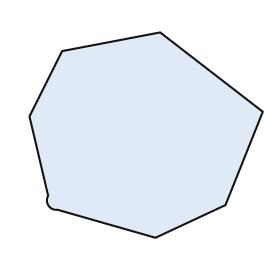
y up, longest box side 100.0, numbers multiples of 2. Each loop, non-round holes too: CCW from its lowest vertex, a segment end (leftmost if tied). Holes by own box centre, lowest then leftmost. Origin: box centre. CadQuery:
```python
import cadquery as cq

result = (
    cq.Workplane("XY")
    .moveTo(4.0, -44.0)
    .lineTo(34.0, -30.0)
    .lineTo(50.0, 10.0)
    .lineTo(6.0, 44.0)
    .lineTo(-36.0, 36.0)
    .lineTo(-50.0, 8.0)
    .lineTo(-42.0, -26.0)
    .threePointArc((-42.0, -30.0), (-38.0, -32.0))
    .close()
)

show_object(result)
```